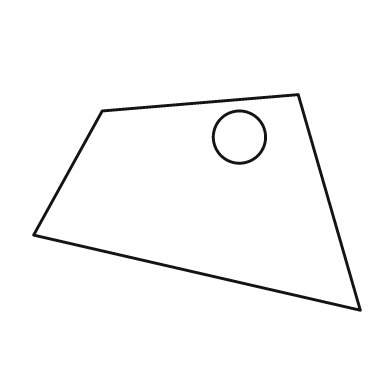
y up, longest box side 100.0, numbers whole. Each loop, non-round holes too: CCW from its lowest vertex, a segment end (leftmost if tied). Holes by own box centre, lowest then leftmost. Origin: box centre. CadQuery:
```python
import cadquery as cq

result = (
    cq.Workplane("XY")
    .moveTo(50.0, -33.0)
    .lineTo(31.0, 33.0)
    .lineTo(-29.0, 28.0)
    .lineTo(-50.0, -10.0)
    .close()
    .moveTo(13.0, 20.0)
    .circle(8.0)
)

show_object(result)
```